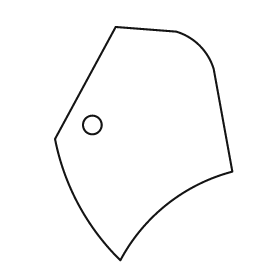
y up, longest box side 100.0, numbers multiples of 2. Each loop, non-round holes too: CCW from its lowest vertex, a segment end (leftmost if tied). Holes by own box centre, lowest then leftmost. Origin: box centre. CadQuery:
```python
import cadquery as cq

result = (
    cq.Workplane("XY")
    .moveTo(-10.0, -50.0)
    .threePointArc((10.0, -26.0), (38.0, -12.0))
    .lineTo(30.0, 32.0)
    .threePointArc((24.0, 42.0), (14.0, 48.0))
    .lineTo(-12.0, 50.0)
    .lineTo(-38.0, 2.0)
    .threePointArc((-28.0, -26.0), (-10.0, -50.0))
    .close()
    .moveTo(-22.0, 8.0)
    .circle(4.0)
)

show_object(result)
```